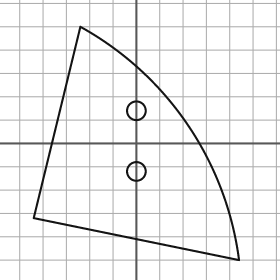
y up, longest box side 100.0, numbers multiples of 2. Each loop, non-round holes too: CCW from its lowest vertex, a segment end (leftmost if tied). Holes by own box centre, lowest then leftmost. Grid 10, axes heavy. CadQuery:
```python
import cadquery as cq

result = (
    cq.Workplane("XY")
    .moveTo(44.0, -50.0)
    .threePointArc((22.0, 8.0), (-24.0, 50.0))
    .lineTo(-44.0, -32.0)
    .close()
    .moveTo(0.0, -12.0)
    .circle(4.0)
    .moveTo(0.0, 14.0)
    .circle(4.0)
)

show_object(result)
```